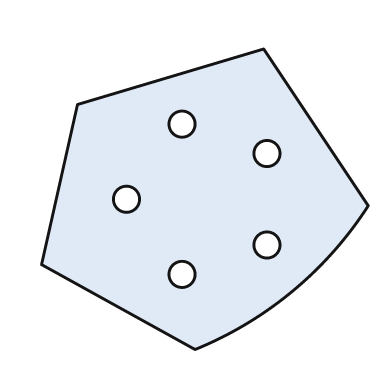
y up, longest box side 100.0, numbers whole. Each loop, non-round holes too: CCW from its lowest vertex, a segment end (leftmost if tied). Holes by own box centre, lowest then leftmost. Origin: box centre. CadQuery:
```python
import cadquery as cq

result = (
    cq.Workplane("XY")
    .moveTo(-3.0, -46.0)
    .threePointArc((27.0, -28.0), (50.0, -2.0))
    .lineTo(18.0, 46.0)
    .lineTo(-39.0, 29.0)
    .lineTo(-50.0, -20.0)
    .close()
    .moveTo(-7.0, -23.0)
    .circle(4.0)
    .moveTo(19.0, -14.0)
    .circle(4.0)
    .moveTo(-24.0, 0.0)
    .circle(4.0)
    .moveTo(19.0, 14.0)
    .circle(4.0)
    .moveTo(-7.0, 23.0)
    .circle(4.0)
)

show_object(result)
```